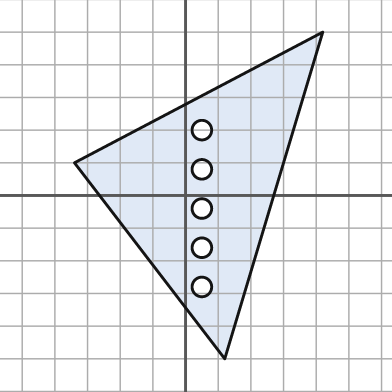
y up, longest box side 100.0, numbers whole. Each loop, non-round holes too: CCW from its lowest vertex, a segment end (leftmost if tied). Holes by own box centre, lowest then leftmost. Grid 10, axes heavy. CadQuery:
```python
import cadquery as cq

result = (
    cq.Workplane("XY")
    .moveTo(12.0, -50.0)
    .lineTo(42.0, 50.0)
    .lineTo(-34.0, 10.0)
    .close()
    .moveTo(5.0, -28.0)
    .circle(3.0)
    .moveTo(5.0, -16.0)
    .circle(3.0)
    .moveTo(5.0, -4.0)
    .circle(3.0)
    .moveTo(5.0, 8.0)
    .circle(3.0)
    .moveTo(5.0, 20.0)
    .circle(3.0)
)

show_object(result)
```